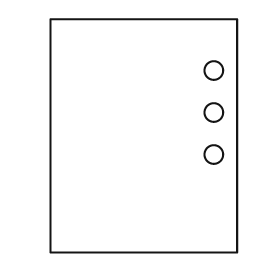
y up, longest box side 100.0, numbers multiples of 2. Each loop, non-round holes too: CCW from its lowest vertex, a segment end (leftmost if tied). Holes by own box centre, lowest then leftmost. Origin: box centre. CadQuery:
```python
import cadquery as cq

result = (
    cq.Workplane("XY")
    .moveTo(-40.0, -50.0)
    .lineTo(40.0, -50.0)
    .lineTo(40.0, 50.0)
    .lineTo(-40.0, 50.0)
    .close()
    .moveTo(30.0, -8.0)
    .circle(4.0)
    .moveTo(30.0, 10.0)
    .circle(4.0)
    .moveTo(30.0, 28.0)
    .circle(4.0)
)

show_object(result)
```